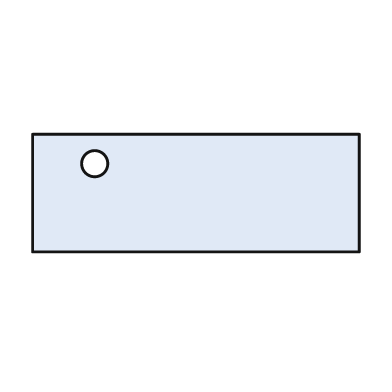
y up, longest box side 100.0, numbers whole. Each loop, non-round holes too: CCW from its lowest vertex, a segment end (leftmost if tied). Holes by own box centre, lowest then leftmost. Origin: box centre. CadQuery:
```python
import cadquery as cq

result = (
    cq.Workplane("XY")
    .moveTo(-50.0, -18.0)
    .lineTo(50.0, -18.0)
    .lineTo(50.0, 18.0)
    .lineTo(-50.0, 18.0)
    .close()
    .moveTo(-31.0, 9.0)
    .circle(4.0)
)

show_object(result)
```